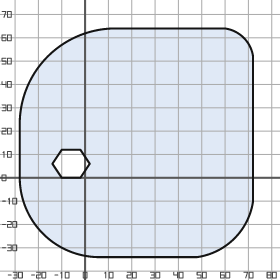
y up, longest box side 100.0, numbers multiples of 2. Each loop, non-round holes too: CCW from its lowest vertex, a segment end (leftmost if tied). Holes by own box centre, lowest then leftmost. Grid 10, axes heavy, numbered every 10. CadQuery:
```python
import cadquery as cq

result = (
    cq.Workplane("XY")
    .moveTo(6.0, -34.0)
    .lineTo(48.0, -34.0)
    .threePointArc((64.0, -26.0), (72.0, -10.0))
    .lineTo(72.0, 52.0)
    .threePointArc((68.0, 60.0), (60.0, 64.0))
    .lineTo(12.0, 64.0)
    .threePointArc((-16.0, 52.0), (-28.0, 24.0))
    .lineTo(-28.0, 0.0)
    .threePointArc((-18.0, -24.0), (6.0, -34.0))
    .close()
    .moveTo(-10.0, 0.0)
    .lineTo(-2.0, 0.0)
    .lineTo(2.0, 6.0)
    .lineTo(-2.0, 12.0)
    .lineTo(-10.0, 12.0)
    .lineTo(-14.0, 6.0)
    .close()
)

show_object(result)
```